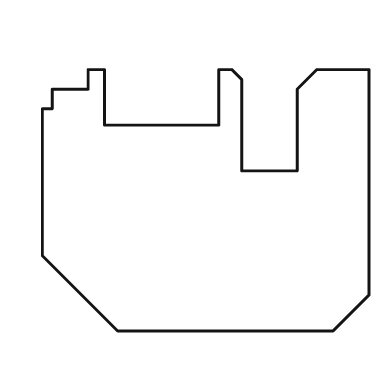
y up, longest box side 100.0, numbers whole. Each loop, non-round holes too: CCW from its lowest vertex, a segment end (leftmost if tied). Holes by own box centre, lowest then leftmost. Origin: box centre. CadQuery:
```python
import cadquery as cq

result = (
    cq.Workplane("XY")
    .moveTo(-27.0, -40.0)
    .lineTo(39.0, -40.0)
    .lineTo(50.0, -29.0)
    .lineTo(50.0, 40.0)
    .lineTo(34.0, 40.0)
    .lineTo(28.0, 34.0)
    .lineTo(28.0, 9.0)
    .lineTo(11.0, 9.0)
    .lineTo(11.0, 37.0)
    .lineTo(8.0, 40.0)
    .lineTo(4.0, 40.0)
    .lineTo(4.0, 23.0)
    .lineTo(-31.0, 23.0)
    .lineTo(-31.0, 40.0)
    .lineTo(-36.0, 40.0)
    .lineTo(-36.0, 34.0)
    .lineTo(-47.0, 34.0)
    .lineTo(-47.0, 28.0)
    .lineTo(-50.0, 28.0)
    .lineTo(-50.0, -17.0)
    .close()
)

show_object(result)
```